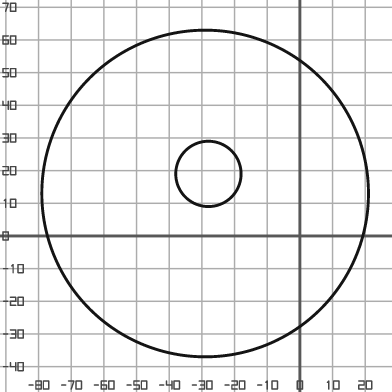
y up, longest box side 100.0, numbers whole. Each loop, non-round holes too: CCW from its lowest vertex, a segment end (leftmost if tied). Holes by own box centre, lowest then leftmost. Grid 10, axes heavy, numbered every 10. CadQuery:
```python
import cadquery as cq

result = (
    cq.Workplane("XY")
    .moveTo(-29.0, 13.0)
    .circle(50.0)
    .moveTo(-28.0, 19.0)
    .circle(10.0)
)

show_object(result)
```